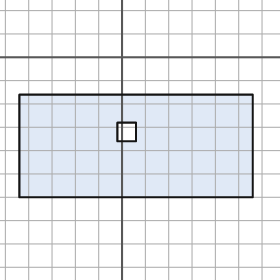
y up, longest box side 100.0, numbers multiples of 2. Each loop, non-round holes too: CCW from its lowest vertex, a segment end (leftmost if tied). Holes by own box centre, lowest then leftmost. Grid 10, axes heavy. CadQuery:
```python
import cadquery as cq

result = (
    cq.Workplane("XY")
    .moveTo(-44.0, -60.0)
    .lineTo(56.0, -60.0)
    .lineTo(56.0, -16.0)
    .lineTo(-44.0, -16.0)
    .close()
    .moveTo(-2.0, -36.0)
    .lineTo(6.0, -36.0)
    .lineTo(6.0, -28.0)
    .lineTo(-2.0, -28.0)
    .close()
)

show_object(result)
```